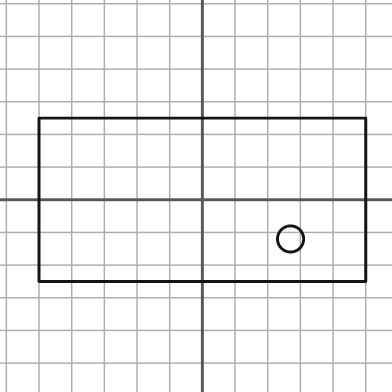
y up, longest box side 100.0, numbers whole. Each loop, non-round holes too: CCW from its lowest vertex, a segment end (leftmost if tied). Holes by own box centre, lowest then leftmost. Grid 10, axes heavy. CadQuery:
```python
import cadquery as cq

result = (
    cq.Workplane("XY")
    .moveTo(-50.0, -25.0)
    .lineTo(50.0, -25.0)
    .lineTo(50.0, 25.0)
    .lineTo(-50.0, 25.0)
    .close()
    .moveTo(27.0, -12.0)
    .circle(4.0)
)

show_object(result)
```